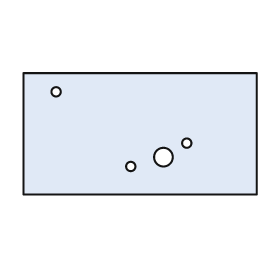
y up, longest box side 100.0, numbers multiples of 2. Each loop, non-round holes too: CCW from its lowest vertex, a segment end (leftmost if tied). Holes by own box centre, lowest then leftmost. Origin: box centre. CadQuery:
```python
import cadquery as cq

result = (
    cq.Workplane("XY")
    .moveTo(-50.0, -26.0)
    .lineTo(50.0, -26.0)
    .lineTo(50.0, 26.0)
    .lineTo(-50.0, 26.0)
    .close()
    .moveTo(-4.0, -14.0)
    .circle(2.0)
    .moveTo(10.0, -10.0)
    .circle(4.0)
    .moveTo(20.0, -4.0)
    .circle(2.0)
    .moveTo(-36.0, 18.0)
    .circle(2.0)
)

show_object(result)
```